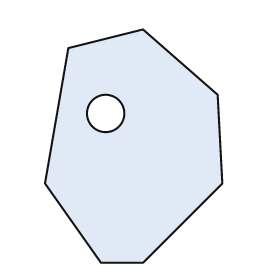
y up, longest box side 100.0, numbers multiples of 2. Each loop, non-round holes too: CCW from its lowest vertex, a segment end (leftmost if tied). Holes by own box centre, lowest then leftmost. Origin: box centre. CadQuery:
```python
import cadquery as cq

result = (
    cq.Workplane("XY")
    .moveTo(-14.0, -50.0)
    .lineTo(4.0, -50.0)
    .lineTo(38.0, -16.0)
    .lineTo(36.0, 22.0)
    .lineTo(4.0, 50.0)
    .lineTo(-28.0, 42.0)
    .lineTo(-38.0, -16.0)
    .close()
    .moveTo(-12.0, 14.0)
    .circle(8.0)
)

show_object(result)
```